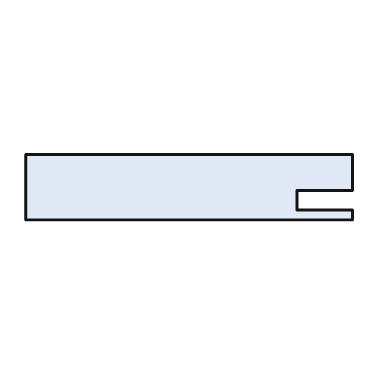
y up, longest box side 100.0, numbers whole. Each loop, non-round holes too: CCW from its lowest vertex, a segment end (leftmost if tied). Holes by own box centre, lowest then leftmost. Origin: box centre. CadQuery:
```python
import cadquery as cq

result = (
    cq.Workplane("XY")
    .moveTo(-50.0, -10.0)
    .lineTo(50.0, -10.0)
    .lineTo(50.0, -7.0)
    .lineTo(33.0, -7.0)
    .lineTo(33.0, -1.0)
    .lineTo(50.0, -1.0)
    .lineTo(50.0, 10.0)
    .lineTo(-50.0, 10.0)
    .close()
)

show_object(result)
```